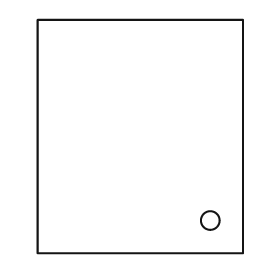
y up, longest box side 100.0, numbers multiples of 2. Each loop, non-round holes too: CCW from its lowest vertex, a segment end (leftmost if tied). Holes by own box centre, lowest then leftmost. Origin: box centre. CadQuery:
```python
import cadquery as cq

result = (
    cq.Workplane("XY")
    .moveTo(-44.0, -50.0)
    .lineTo(44.0, -50.0)
    .lineTo(44.0, 50.0)
    .lineTo(-44.0, 50.0)
    .close()
    .moveTo(30.0, -36.0)
    .circle(4.0)
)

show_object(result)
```